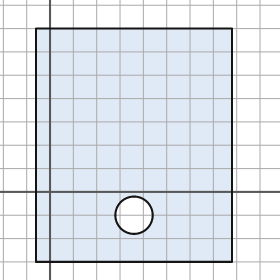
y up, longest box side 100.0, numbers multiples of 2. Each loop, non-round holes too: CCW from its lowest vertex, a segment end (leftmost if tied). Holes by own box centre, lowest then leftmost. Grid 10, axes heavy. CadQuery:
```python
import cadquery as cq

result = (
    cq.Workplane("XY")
    .moveTo(-6.0, -30.0)
    .lineTo(78.0, -30.0)
    .lineTo(78.0, 70.0)
    .lineTo(-6.0, 70.0)
    .close()
    .moveTo(36.0, -10.0)
    .circle(8.0)
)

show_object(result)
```